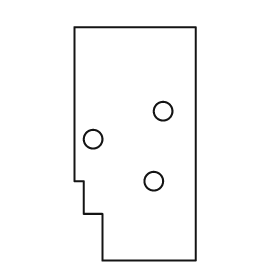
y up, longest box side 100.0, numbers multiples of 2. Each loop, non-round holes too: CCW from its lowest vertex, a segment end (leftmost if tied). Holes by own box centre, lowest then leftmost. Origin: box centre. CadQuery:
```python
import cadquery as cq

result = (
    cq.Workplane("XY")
    .moveTo(-14.0, -50.0)
    .lineTo(26.0, -50.0)
    .lineTo(26.0, 50.0)
    .lineTo(-26.0, 50.0)
    .lineTo(-26.0, -16.0)
    .lineTo(-22.0, -16.0)
    .lineTo(-22.0, -30.0)
    .lineTo(-14.0, -30.0)
    .close()
    .moveTo(8.0, -16.0)
    .circle(4.0)
    .moveTo(-18.0, 2.0)
    .circle(4.0)
    .moveTo(12.0, 14.0)
    .circle(4.0)
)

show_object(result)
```